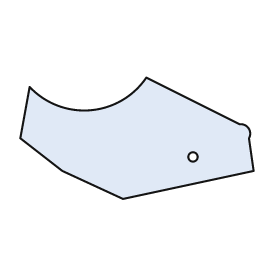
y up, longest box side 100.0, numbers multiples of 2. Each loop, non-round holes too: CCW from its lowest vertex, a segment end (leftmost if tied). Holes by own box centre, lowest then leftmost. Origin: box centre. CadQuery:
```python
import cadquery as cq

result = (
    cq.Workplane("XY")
    .moveTo(-6.0, -26.0)
    .lineTo(50.0, -14.0)
    .lineTo(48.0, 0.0)
    .threePointArc((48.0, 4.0), (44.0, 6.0))
    .lineTo(4.0, 26.0)
    .threePointArc((-20.0, 12.0), (-46.0, 22.0))
    .lineTo(-50.0, 0.0)
    .lineTo(-32.0, -14.0)
    .close()
    .moveTo(24.0, -8.0)
    .circle(2.0)
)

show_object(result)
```